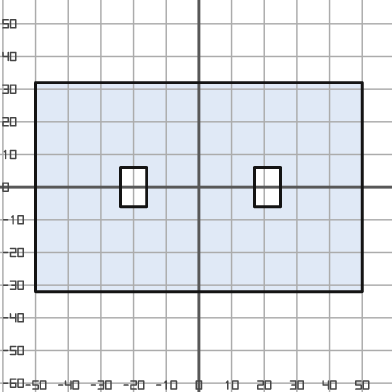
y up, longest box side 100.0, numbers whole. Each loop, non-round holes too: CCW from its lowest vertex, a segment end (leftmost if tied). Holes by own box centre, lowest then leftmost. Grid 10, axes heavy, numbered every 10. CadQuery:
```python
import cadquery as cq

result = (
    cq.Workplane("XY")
    .moveTo(-50.0, -32.0)
    .lineTo(50.0, -32.0)
    .lineTo(50.0, 32.0)
    .lineTo(-50.0, 32.0)
    .close()
    .moveTo(-24.0, -6.0)
    .lineTo(-16.0, -6.0)
    .lineTo(-16.0, 6.0)
    .lineTo(-24.0, 6.0)
    .close()
    .moveTo(17.0, -6.0)
    .lineTo(25.0, -6.0)
    .lineTo(25.0, 6.0)
    .lineTo(17.0, 6.0)
    .close()
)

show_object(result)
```